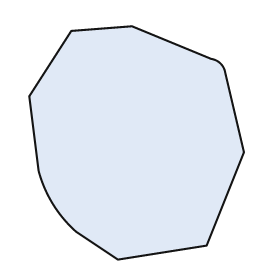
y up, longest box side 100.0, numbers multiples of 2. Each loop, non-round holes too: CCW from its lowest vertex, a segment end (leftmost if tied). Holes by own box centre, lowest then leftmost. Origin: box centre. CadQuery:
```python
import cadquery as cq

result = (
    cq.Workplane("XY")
    .moveTo(-8.0, -50.0)
    .lineTo(30.0, -44.0)
    .lineTo(46.0, -4.0)
    .lineTo(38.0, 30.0)
    .threePointArc((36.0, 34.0), (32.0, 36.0))
    .lineTo(-2.0, 50.0)
    .lineTo(-28.0, 48.0)
    .lineTo(-46.0, 20.0)
    .lineTo(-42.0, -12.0)
    .threePointArc((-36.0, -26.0), (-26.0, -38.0))
    .close()
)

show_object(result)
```